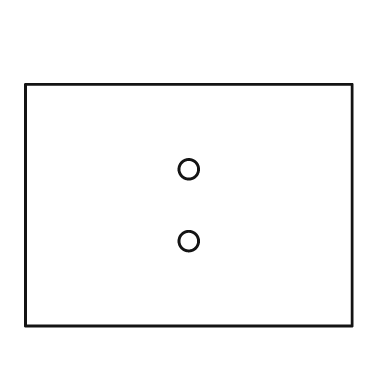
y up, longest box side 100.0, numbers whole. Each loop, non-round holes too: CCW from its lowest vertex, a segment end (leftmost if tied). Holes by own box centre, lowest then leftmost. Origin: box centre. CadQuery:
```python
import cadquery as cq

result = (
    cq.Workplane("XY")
    .moveTo(-50.0, -37.0)
    .lineTo(50.0, -37.0)
    .lineTo(50.0, 37.0)
    .lineTo(-50.0, 37.0)
    .close()
    .moveTo(0.0, -11.0)
    .circle(3.0)
    .moveTo(0.0, 11.0)
    .circle(3.0)
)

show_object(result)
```